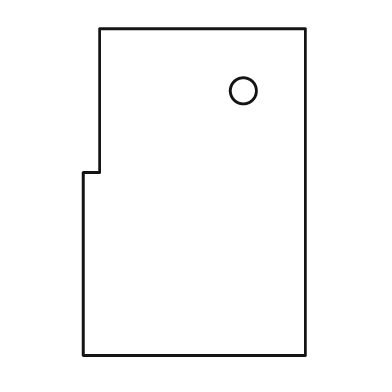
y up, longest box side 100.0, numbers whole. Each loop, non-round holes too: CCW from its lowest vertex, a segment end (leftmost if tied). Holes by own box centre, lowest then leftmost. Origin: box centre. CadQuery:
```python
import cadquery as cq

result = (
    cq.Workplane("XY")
    .moveTo(-34.0, -50.0)
    .lineTo(34.0, -50.0)
    .lineTo(34.0, 50.0)
    .lineTo(-29.0, 50.0)
    .lineTo(-29.0, 6.0)
    .lineTo(-34.0, 6.0)
    .close()
    .moveTo(15.0, 31.0)
    .circle(4.0)
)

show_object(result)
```